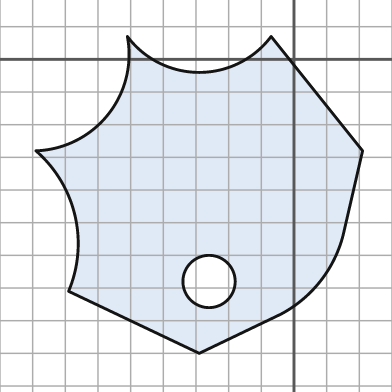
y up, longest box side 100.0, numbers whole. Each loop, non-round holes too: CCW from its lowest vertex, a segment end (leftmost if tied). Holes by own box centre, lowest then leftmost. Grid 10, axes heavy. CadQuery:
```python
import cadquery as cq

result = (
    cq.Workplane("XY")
    .moveTo(-29.0, -90.0)
    .lineTo(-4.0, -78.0)
    .threePointArc((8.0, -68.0), (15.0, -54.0))
    .lineTo(21.0, -28.0)
    .lineTo(-7.0, 7.0)
    .threePointArc((-29.0, -4.0), (-51.0, 7.0))
    .threePointArc((-57.0, -17.0), (-79.0, -28.0))
    .threePointArc((-67.0, -48.0), (-69.0, -71.0))
    .close()
    .moveTo(-26.0, -68.0)
    .circle(8.0)
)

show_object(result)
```